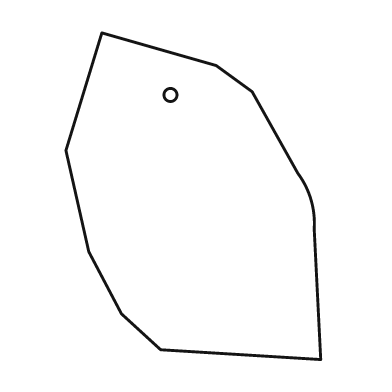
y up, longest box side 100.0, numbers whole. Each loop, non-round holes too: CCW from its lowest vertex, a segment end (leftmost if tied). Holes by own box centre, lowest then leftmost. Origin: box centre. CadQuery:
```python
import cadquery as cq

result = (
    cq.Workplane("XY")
    .moveTo(39.0, -50.0)
    .lineTo(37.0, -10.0)
    .threePointArc((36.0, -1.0), (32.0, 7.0))
    .lineTo(18.0, 32.0)
    .lineTo(7.0, 40.0)
    .lineTo(-28.0, 50.0)
    .lineTo(-39.0, 14.0)
    .lineTo(-32.0, -17.0)
    .lineTo(-22.0, -36.0)
    .lineTo(-10.0, -47.0)
    .close()
    .moveTo(-7.0, 31.0)
    .circle(2.0)
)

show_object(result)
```